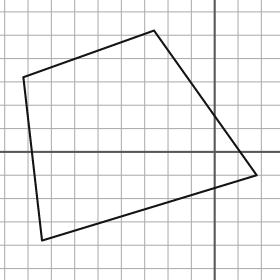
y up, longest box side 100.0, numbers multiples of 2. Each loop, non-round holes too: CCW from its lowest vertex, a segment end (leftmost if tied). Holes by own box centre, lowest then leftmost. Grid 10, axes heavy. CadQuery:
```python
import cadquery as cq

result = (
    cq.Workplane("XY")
    .moveTo(-74.0, -38.0)
    .lineTo(18.0, -10.0)
    .lineTo(-26.0, 52.0)
    .lineTo(-82.0, 32.0)
    .close()
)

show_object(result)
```